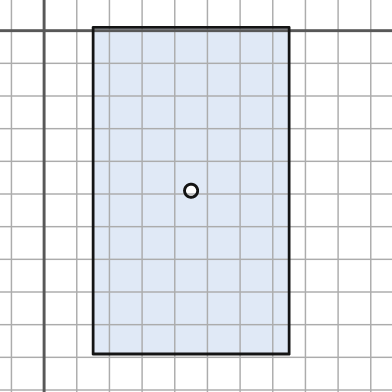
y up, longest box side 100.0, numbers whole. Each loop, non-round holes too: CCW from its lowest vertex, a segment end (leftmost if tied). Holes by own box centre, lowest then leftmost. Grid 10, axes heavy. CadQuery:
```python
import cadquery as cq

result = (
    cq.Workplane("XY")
    .moveTo(15.0, -99.0)
    .lineTo(75.0, -99.0)
    .lineTo(75.0, 1.0)
    .lineTo(15.0, 1.0)
    .close()
    .moveTo(45.0, -49.0)
    .circle(2.0)
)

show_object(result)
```